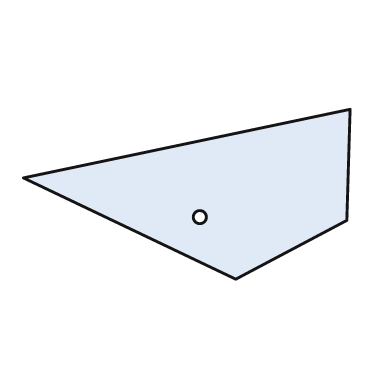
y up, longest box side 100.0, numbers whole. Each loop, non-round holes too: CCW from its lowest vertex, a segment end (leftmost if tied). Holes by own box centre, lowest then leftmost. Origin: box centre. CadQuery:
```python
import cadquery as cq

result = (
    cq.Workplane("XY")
    .moveTo(15.0, -26.0)
    .lineTo(49.0, -8.0)
    .lineTo(50.0, 26.0)
    .lineTo(-50.0, 5.0)
    .close()
    .moveTo(4.0, -7.0)
    .circle(2.0)
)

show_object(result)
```